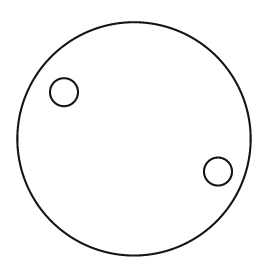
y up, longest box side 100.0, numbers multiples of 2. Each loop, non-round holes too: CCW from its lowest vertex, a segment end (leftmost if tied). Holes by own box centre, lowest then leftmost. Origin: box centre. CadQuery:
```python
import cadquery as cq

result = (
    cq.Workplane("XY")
    .moveTo(0.0, 0.0)
    .circle(50.0)
    .moveTo(36.0, -14.0)
    .circle(6.0)
    .moveTo(-30.0, 20.0)
    .circle(6.0)
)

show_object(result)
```